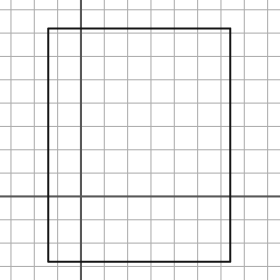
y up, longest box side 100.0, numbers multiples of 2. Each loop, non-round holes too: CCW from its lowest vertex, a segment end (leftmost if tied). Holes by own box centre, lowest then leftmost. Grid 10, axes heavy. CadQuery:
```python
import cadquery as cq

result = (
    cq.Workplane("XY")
    .moveTo(-14.0, -28.0)
    .lineTo(64.0, -28.0)
    .lineTo(64.0, 72.0)
    .lineTo(-14.0, 72.0)
    .close()
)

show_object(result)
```